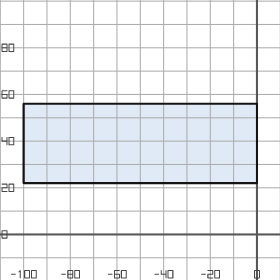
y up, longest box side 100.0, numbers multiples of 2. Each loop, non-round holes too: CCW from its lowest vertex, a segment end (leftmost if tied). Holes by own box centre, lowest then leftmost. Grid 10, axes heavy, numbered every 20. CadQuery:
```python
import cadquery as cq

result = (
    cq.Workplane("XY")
    .moveTo(-100.0, 22.0)
    .lineTo(0.0, 22.0)
    .lineTo(0.0, 56.0)
    .lineTo(-100.0, 56.0)
    .close()
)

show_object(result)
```